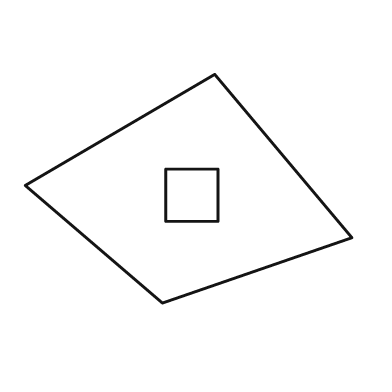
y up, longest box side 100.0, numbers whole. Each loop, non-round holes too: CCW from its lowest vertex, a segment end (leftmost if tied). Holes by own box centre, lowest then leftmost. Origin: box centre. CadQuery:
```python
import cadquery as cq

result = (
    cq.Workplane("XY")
    .moveTo(-8.0, -35.0)
    .lineTo(50.0, -15.0)
    .lineTo(8.0, 35.0)
    .lineTo(-50.0, 1.0)
    .close()
    .moveTo(-7.0, -10.0)
    .lineTo(9.0, -10.0)
    .lineTo(9.0, 6.0)
    .lineTo(-7.0, 6.0)
    .close()
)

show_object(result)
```